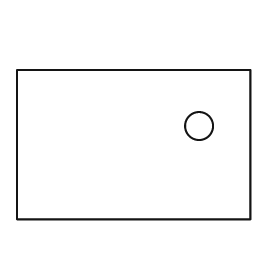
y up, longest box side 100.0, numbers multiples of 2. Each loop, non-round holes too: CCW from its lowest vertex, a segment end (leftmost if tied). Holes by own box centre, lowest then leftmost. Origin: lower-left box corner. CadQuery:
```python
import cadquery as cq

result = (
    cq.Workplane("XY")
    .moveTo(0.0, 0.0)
    .lineTo(100.0, 0.0)
    .lineTo(100.0, 64.0)
    .lineTo(0.0, 64.0)
    .close()
    .moveTo(78.0, 40.0)
    .circle(6.0)
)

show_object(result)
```